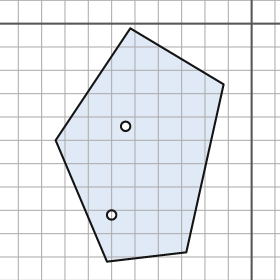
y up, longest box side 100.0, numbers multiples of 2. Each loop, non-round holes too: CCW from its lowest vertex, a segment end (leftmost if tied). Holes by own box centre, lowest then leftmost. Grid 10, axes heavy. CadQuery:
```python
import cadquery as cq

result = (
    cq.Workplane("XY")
    .moveTo(-62.0, -102.0)
    .lineTo(-28.0, -98.0)
    .lineTo(-12.0, -26.0)
    .lineTo(-52.0, -2.0)
    .lineTo(-84.0, -50.0)
    .close()
    .moveTo(-60.0, -82.0)
    .circle(2.0)
    .moveTo(-54.0, -44.0)
    .circle(2.0)
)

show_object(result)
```